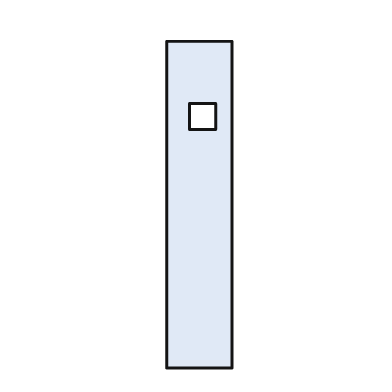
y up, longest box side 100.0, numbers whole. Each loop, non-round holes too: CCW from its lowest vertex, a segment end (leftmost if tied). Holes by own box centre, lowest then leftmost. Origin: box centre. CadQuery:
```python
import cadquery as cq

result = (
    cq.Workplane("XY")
    .moveTo(-10.0, -50.0)
    .lineTo(10.0, -50.0)
    .lineTo(10.0, 50.0)
    .lineTo(-10.0, 50.0)
    .close()
    .moveTo(-3.0, 23.0)
    .lineTo(5.0, 23.0)
    .lineTo(5.0, 31.0)
    .lineTo(-3.0, 31.0)
    .close()
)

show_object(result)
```